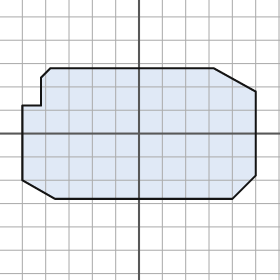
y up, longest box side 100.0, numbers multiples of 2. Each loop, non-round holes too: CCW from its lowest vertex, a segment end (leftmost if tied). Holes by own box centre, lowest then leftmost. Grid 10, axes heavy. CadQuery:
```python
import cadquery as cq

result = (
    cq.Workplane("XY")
    .moveTo(-36.0, -28.0)
    .lineTo(40.0, -28.0)
    .lineTo(50.0, -18.0)
    .lineTo(50.0, 18.0)
    .lineTo(32.0, 28.0)
    .lineTo(-38.0, 28.0)
    .lineTo(-42.0, 24.0)
    .lineTo(-42.0, 12.0)
    .lineTo(-50.0, 12.0)
    .lineTo(-50.0, -20.0)
    .close()
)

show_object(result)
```